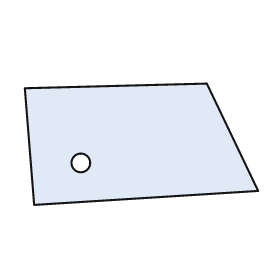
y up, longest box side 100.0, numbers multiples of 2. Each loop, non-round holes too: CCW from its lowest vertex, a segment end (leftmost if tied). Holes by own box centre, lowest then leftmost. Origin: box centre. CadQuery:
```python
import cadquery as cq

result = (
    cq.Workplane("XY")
    .moveTo(-46.0, -26.0)
    .lineTo(50.0, -20.0)
    .lineTo(28.0, 26.0)
    .lineTo(-50.0, 24.0)
    .close()
    .moveTo(-26.0, -8.0)
    .circle(4.0)
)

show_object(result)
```